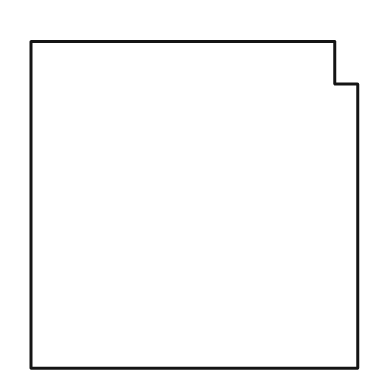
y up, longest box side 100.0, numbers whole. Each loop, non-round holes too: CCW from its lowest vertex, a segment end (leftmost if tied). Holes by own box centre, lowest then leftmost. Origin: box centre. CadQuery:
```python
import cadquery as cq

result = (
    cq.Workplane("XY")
    .moveTo(-50.0, -50.0)
    .lineTo(50.0, -50.0)
    .lineTo(50.0, 37.0)
    .lineTo(43.0, 37.0)
    .lineTo(43.0, 50.0)
    .lineTo(-50.0, 50.0)
    .close()
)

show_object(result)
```